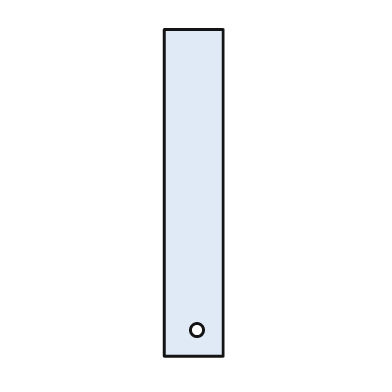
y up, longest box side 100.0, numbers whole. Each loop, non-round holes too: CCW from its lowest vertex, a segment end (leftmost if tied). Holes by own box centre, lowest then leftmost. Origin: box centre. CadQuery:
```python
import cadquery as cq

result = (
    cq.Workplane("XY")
    .moveTo(-9.0, -50.0)
    .lineTo(9.0, -50.0)
    .lineTo(9.0, 50.0)
    .lineTo(-9.0, 50.0)
    .close()
    .moveTo(1.0, -42.0)
    .circle(2.0)
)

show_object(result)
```